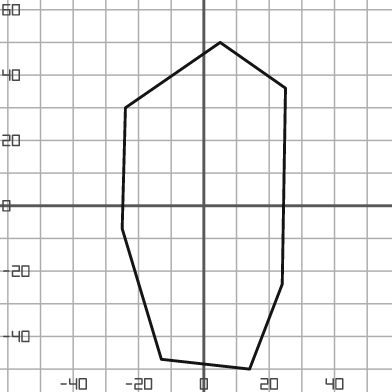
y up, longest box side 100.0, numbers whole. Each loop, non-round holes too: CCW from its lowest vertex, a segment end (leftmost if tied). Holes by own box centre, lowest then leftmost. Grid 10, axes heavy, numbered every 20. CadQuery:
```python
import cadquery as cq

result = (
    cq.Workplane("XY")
    .moveTo(14.0, -50.0)
    .lineTo(24.0, -24.0)
    .lineTo(25.0, 36.0)
    .lineTo(5.0, 50.0)
    .lineTo(-24.0, 30.0)
    .lineTo(-25.0, -7.0)
    .lineTo(-13.0, -47.0)
    .close()
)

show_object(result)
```